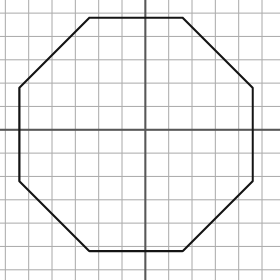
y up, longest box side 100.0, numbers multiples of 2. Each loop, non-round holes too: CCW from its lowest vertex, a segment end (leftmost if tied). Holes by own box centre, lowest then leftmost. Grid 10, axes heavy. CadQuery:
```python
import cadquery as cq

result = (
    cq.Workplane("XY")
    .moveTo(-24.0, -52.0)
    .lineTo(16.0, -52.0)
    .lineTo(46.0, -22.0)
    .lineTo(46.0, 18.0)
    .lineTo(16.0, 48.0)
    .lineTo(-24.0, 48.0)
    .lineTo(-54.0, 18.0)
    .lineTo(-54.0, -22.0)
    .close()
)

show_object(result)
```